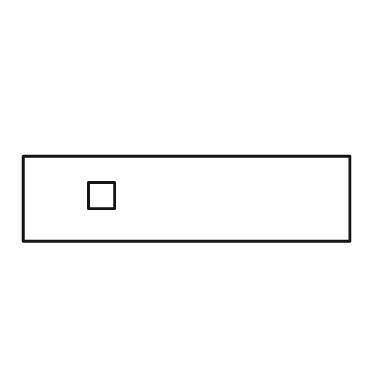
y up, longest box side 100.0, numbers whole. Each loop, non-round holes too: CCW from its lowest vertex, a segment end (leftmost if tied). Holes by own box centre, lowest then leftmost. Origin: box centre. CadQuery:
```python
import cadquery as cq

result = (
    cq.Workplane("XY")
    .moveTo(-50.0, -13.0)
    .lineTo(50.0, -13.0)
    .lineTo(50.0, 13.0)
    .lineTo(-50.0, 13.0)
    .close()
    .moveTo(-30.0, -3.0)
    .lineTo(-22.0, -3.0)
    .lineTo(-22.0, 5.0)
    .lineTo(-30.0, 5.0)
    .close()
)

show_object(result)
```